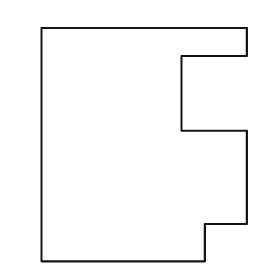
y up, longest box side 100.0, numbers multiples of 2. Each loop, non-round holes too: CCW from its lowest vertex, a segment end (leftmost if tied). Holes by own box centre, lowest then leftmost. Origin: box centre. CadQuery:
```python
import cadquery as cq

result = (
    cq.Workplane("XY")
    .moveTo(-44.0, -50.0)
    .lineTo(26.0, -50.0)
    .lineTo(26.0, -34.0)
    .lineTo(44.0, -34.0)
    .lineTo(44.0, 6.0)
    .lineTo(16.0, 6.0)
    .lineTo(16.0, 38.0)
    .lineTo(44.0, 38.0)
    .lineTo(44.0, 50.0)
    .lineTo(-44.0, 50.0)
    .close()
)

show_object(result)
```